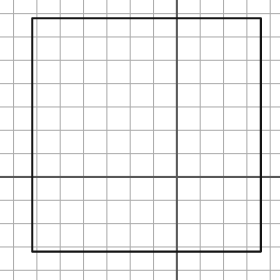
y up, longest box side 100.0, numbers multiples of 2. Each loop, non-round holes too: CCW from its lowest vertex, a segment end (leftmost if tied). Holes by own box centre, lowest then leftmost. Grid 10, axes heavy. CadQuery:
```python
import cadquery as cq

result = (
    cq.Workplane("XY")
    .moveTo(-62.0, -32.0)
    .lineTo(36.0, -32.0)
    .lineTo(36.0, 68.0)
    .lineTo(-62.0, 68.0)
    .close()
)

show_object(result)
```